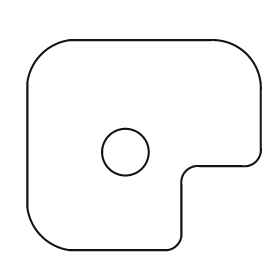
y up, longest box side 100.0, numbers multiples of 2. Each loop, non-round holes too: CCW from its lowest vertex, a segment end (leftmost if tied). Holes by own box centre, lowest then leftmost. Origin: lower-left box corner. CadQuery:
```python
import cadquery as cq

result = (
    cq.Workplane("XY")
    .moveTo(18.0, 0.0)
    .lineTo(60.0, 0.0)
    .threePointArc((64.0, 2.0), (66.0, 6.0))
    .lineTo(66.0, 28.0)
    .threePointArc((68.0, 34.0), (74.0, 36.0))
    .lineTo(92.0, 36.0)
    .threePointArc((98.0, 38.0), (100.0, 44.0))
    .lineTo(100.0, 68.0)
    .threePointArc((94.0, 84.0), (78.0, 90.0))
    .lineTo(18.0, 90.0)
    .threePointArc((6.0, 84.0), (0.0, 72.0))
    .lineTo(0.0, 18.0)
    .threePointArc((6.0, 6.0), (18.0, 0.0))
    .close()
    .moveTo(42.0, 42.0)
    .circle(10.0)
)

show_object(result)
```